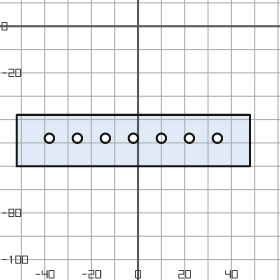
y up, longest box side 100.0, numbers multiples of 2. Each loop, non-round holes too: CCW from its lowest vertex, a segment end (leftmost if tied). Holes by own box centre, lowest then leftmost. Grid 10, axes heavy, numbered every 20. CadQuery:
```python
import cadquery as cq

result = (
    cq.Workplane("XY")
    .moveTo(-52.0, -60.0)
    .lineTo(48.0, -60.0)
    .lineTo(48.0, -38.0)
    .lineTo(-52.0, -38.0)
    .close()
    .moveTo(-38.0, -48.0)
    .circle(2.0)
    .moveTo(-26.0, -48.0)
    .circle(2.0)
    .moveTo(-14.0, -48.0)
    .circle(2.0)
    .moveTo(-2.0, -48.0)
    .circle(2.0)
    .moveTo(10.0, -48.0)
    .circle(2.0)
    .moveTo(22.0, -48.0)
    .circle(2.0)
    .moveTo(34.0, -48.0)
    .circle(2.0)
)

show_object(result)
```